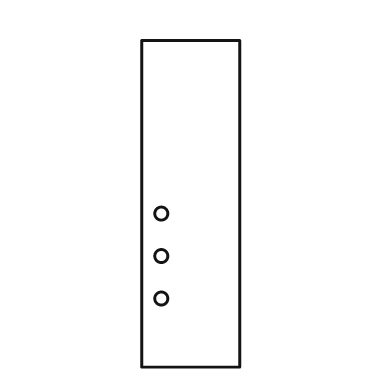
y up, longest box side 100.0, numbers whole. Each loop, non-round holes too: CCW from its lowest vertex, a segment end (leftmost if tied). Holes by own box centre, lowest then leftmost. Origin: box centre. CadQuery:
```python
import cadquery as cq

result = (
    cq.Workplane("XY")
    .moveTo(-15.0, -50.0)
    .lineTo(15.0, -50.0)
    .lineTo(15.0, 50.0)
    .lineTo(-15.0, 50.0)
    .close()
    .moveTo(-9.0, -29.0)
    .circle(2.0)
    .moveTo(-9.0, -16.0)
    .circle(2.0)
    .moveTo(-9.0, -3.0)
    .circle(2.0)
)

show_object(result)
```